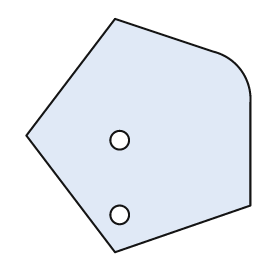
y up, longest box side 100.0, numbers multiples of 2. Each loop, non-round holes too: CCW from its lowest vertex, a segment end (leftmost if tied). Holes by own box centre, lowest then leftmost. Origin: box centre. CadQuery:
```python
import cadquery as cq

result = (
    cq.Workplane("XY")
    .moveTo(-10.0, -50.0)
    .lineTo(48.0, -30.0)
    .lineTo(48.0, 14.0)
    .threePointArc((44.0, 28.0), (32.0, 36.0))
    .lineTo(-10.0, 50.0)
    .lineTo(-48.0, 0.0)
    .close()
    .moveTo(-8.0, -34.0)
    .circle(4.0)
    .moveTo(-8.0, -2.0)
    .circle(4.0)
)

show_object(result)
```